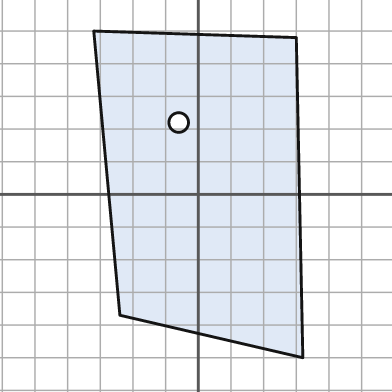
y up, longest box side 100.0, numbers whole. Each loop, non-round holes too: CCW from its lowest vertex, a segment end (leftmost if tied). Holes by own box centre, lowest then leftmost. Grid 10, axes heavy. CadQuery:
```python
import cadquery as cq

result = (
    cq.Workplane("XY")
    .moveTo(32.0, -50.0)
    .lineTo(30.0, 48.0)
    .lineTo(-32.0, 50.0)
    .lineTo(-24.0, -37.0)
    .close()
    .moveTo(-6.0, 22.0)
    .circle(3.0)
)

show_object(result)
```